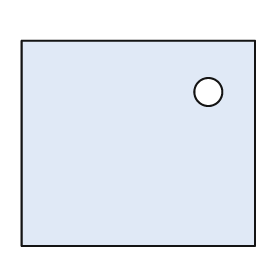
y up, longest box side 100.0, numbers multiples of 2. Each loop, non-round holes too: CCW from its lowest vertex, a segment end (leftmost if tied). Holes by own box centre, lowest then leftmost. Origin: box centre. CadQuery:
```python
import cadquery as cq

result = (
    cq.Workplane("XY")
    .moveTo(-50.0, -44.0)
    .lineTo(50.0, -44.0)
    .lineTo(50.0, 44.0)
    .lineTo(-50.0, 44.0)
    .close()
    .moveTo(30.0, 22.0)
    .circle(6.0)
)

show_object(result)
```